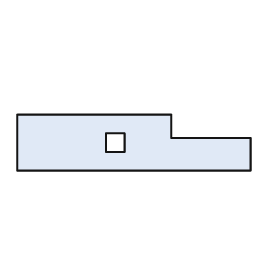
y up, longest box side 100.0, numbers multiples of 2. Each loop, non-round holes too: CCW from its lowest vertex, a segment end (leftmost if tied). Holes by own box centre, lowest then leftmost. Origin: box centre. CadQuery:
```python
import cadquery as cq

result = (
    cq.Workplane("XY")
    .moveTo(-50.0, -12.0)
    .lineTo(50.0, -12.0)
    .lineTo(50.0, 2.0)
    .lineTo(16.0, 2.0)
    .lineTo(16.0, 12.0)
    .lineTo(-50.0, 12.0)
    .close()
    .moveTo(-12.0, -4.0)
    .lineTo(-4.0, -4.0)
    .lineTo(-4.0, 4.0)
    .lineTo(-12.0, 4.0)
    .close()
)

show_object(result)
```